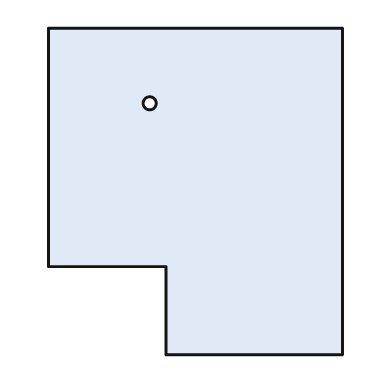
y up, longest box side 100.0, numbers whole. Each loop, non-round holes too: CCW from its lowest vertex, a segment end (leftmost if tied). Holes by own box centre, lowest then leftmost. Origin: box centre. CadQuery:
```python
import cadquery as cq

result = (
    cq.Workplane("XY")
    .moveTo(-9.0, -50.0)
    .lineTo(45.0, -50.0)
    .lineTo(45.0, 50.0)
    .lineTo(-45.0, 50.0)
    .lineTo(-45.0, -23.0)
    .lineTo(-9.0, -23.0)
    .close()
    .moveTo(-14.0, 27.0)
    .circle(2.0)
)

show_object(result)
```